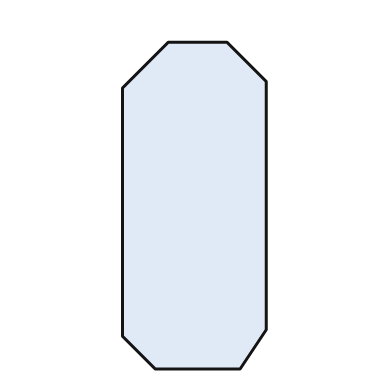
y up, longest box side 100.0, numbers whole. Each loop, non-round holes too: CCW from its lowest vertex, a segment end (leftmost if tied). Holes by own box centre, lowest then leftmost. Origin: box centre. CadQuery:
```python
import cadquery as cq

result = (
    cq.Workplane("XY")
    .moveTo(-12.0, -50.0)
    .lineTo(14.0, -50.0)
    .lineTo(22.0, -38.0)
    .lineTo(22.0, 38.0)
    .lineTo(10.0, 50.0)
    .lineTo(-8.0, 50.0)
    .lineTo(-22.0, 36.0)
    .lineTo(-22.0, -40.0)
    .close()
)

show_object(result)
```